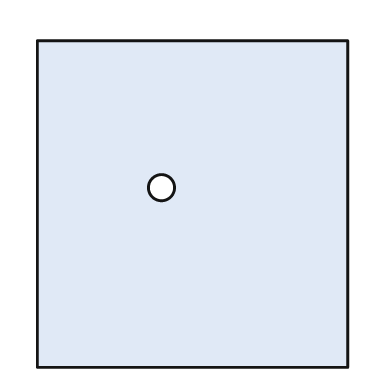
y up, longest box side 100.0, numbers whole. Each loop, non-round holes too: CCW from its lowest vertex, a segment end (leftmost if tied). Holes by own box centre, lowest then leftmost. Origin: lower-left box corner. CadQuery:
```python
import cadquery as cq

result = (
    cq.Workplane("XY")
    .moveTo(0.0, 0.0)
    .lineTo(95.0, 0.0)
    .lineTo(95.0, 100.0)
    .lineTo(0.0, 100.0)
    .close()
    .moveTo(38.0, 55.0)
    .circle(4.0)
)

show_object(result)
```